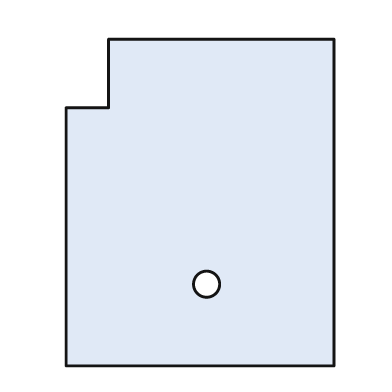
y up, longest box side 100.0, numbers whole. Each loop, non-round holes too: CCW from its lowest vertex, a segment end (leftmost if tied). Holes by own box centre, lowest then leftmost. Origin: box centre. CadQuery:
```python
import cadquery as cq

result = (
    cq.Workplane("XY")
    .moveTo(-41.0, -50.0)
    .lineTo(41.0, -50.0)
    .lineTo(41.0, 50.0)
    .lineTo(-28.0, 50.0)
    .lineTo(-28.0, 29.0)
    .lineTo(-41.0, 29.0)
    .close()
    .moveTo(2.0, -25.0)
    .circle(4.0)
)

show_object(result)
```